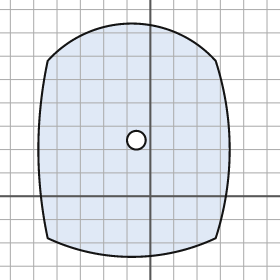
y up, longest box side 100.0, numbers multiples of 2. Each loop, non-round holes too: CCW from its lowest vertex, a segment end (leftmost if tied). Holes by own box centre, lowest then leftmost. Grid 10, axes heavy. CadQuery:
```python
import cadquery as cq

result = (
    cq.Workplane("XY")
    .moveTo(-44.0, -18.0)
    .threePointArc((-8.0, -26.0), (28.0, -18.0))
    .threePointArc((34.0, 20.0), (28.0, 58.0))
    .threePointArc((-8.0, 74.0), (-44.0, 58.0))
    .threePointArc((-48.0, 20.0), (-44.0, -18.0))
    .close()
    .moveTo(-6.0, 24.0)
    .circle(4.0)
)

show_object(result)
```